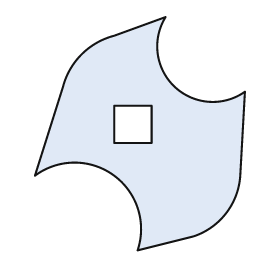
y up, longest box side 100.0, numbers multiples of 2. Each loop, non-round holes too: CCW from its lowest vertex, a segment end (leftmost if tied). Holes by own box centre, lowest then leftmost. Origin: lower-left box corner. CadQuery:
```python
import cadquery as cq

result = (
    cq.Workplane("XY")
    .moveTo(44.0, 0.0)
    .lineTo(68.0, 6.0)
    .threePointArc((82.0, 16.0), (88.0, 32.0))
    .lineTo(90.0, 68.0)
    .threePointArc((60.0, 70.0), (56.0, 100.0))
    .lineTo(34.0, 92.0)
    .threePointArc((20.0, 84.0), (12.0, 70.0))
    .lineTo(0.0, 32.0)
    .threePointArc((34.0, 32.0), (44.0, 0.0))
    .close()
    .moveTo(34.0, 46.0)
    .lineTo(50.0, 46.0)
    .lineTo(50.0, 62.0)
    .lineTo(34.0, 62.0)
    .close()
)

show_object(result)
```